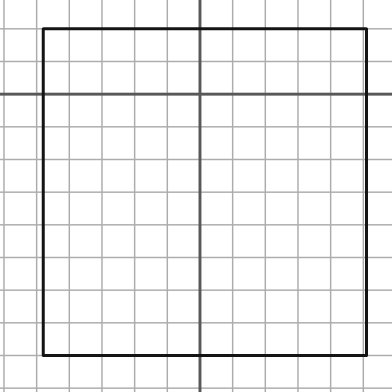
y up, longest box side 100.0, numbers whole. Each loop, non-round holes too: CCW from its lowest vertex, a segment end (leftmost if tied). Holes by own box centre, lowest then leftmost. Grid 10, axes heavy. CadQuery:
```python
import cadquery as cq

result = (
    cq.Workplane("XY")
    .moveTo(-48.0, -80.0)
    .lineTo(51.0, -80.0)
    .lineTo(51.0, 20.0)
    .lineTo(-48.0, 20.0)
    .close()
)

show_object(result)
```